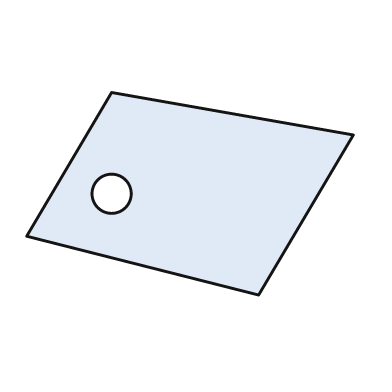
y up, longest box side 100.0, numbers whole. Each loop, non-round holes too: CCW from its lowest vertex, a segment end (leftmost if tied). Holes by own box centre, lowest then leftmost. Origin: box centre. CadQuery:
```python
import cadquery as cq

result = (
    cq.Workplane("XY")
    .moveTo(21.0, -31.0)
    .lineTo(50.0, 18.0)
    .lineTo(-24.0, 31.0)
    .lineTo(-50.0, -13.0)
    .close()
    .moveTo(-24.0, 0.0)
    .circle(6.0)
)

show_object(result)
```